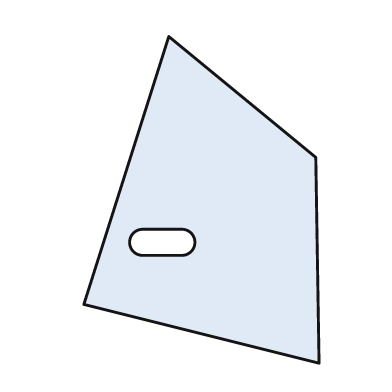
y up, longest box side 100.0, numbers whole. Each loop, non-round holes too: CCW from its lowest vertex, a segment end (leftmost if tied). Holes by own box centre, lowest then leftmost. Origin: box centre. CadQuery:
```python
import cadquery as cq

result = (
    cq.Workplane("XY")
    .moveTo(36.0, -50.0)
    .lineTo(35.0, 13.0)
    .lineTo(-10.0, 50.0)
    .lineTo(-36.0, -32.0)
    .close()
    .moveTo(-18.0, -17.0)
    .lineTo(-6.0, -17.0)
    .threePointArc((-2.0, -13.0), (-6.0, -9.0))
    .lineTo(-18.0, -9.0)
    .threePointArc((-22.0, -13.0), (-18.0, -17.0))
    .close()
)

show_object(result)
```